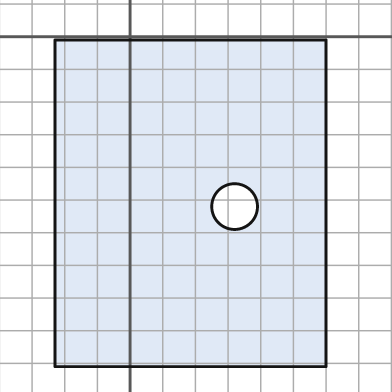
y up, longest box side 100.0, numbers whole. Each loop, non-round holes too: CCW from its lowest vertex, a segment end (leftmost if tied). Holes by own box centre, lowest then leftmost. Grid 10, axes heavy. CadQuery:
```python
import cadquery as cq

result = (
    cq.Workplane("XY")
    .moveTo(-23.0, -101.0)
    .lineTo(60.0, -101.0)
    .lineTo(60.0, -1.0)
    .lineTo(-23.0, -1.0)
    .close()
    .moveTo(32.0, -52.0)
    .circle(7.0)
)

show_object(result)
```